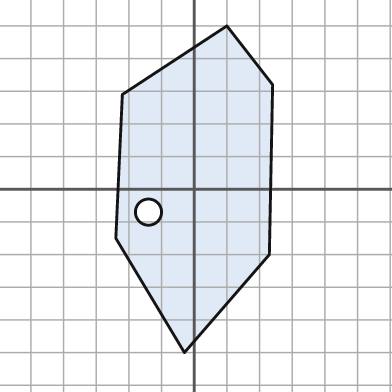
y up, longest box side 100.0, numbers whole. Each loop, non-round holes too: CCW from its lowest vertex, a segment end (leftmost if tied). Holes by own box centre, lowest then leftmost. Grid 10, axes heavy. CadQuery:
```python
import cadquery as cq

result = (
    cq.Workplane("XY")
    .moveTo(-3.0, -50.0)
    .lineTo(23.0, -20.0)
    .lineTo(24.0, 32.0)
    .lineTo(10.0, 50.0)
    .lineTo(-22.0, 29.0)
    .lineTo(-24.0, -15.0)
    .close()
    .moveTo(-14.0, -7.0)
    .circle(4.0)
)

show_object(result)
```